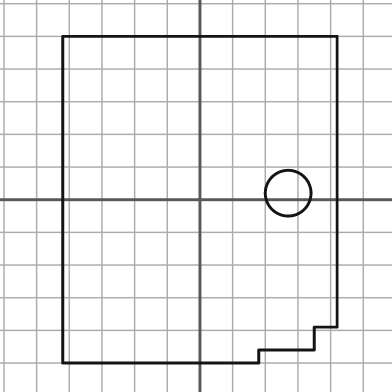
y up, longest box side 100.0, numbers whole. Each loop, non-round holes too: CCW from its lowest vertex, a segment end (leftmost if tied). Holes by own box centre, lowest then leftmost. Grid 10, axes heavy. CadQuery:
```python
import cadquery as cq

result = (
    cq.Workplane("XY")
    .moveTo(-42.0, -50.0)
    .lineTo(18.0, -50.0)
    .lineTo(18.0, -46.0)
    .lineTo(35.0, -46.0)
    .lineTo(35.0, -39.0)
    .lineTo(42.0, -39.0)
    .lineTo(42.0, 50.0)
    .lineTo(-42.0, 50.0)
    .close()
    .moveTo(27.0, 2.0)
    .circle(7.0)
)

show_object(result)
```